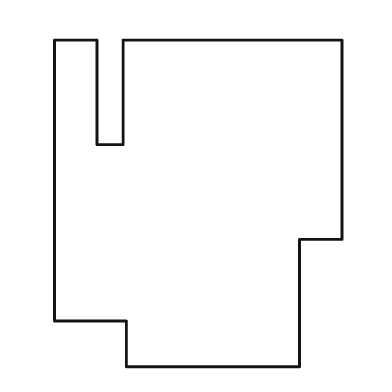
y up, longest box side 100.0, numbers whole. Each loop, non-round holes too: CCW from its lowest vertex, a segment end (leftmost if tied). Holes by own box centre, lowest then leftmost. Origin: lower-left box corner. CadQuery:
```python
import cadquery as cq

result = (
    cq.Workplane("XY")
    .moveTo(22.0, 0.0)
    .lineTo(75.0, 0.0)
    .lineTo(75.0, 39.0)
    .lineTo(88.0, 39.0)
    .lineTo(88.0, 100.0)
    .lineTo(21.0, 100.0)
    .lineTo(21.0, 68.0)
    .lineTo(13.0, 68.0)
    .lineTo(13.0, 100.0)
    .lineTo(0.0, 100.0)
    .lineTo(0.0, 14.0)
    .lineTo(22.0, 14.0)
    .close()
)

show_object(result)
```